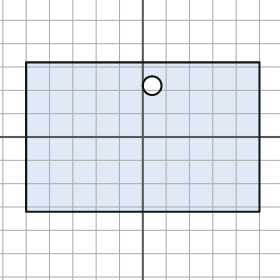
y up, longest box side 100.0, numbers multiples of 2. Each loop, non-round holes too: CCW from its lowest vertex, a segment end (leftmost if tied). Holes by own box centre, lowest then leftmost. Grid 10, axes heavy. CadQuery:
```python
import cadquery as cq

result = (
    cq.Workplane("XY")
    .moveTo(-50.0, -32.0)
    .lineTo(50.0, -32.0)
    .lineTo(50.0, 32.0)
    .lineTo(-50.0, 32.0)
    .close()
    .moveTo(4.0, 22.0)
    .circle(4.0)
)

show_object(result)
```